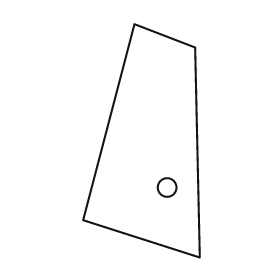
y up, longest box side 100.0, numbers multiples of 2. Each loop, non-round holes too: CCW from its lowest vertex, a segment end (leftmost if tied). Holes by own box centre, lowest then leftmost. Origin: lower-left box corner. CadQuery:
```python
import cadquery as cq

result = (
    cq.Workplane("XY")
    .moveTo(50.0, 0.0)
    .lineTo(48.0, 90.0)
    .lineTo(22.0, 100.0)
    .lineTo(0.0, 16.0)
    .close()
    .moveTo(36.0, 30.0)
    .circle(4.0)
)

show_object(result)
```